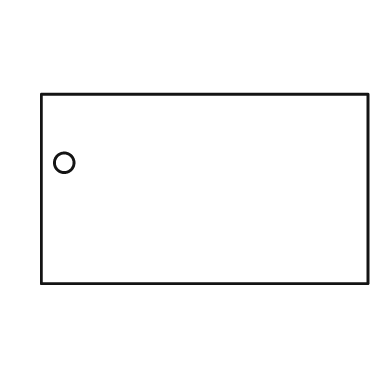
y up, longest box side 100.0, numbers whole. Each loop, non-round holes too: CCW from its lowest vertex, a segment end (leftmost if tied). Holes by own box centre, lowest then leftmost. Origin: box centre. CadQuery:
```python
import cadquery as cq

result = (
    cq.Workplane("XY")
    .moveTo(-50.0, -29.0)
    .lineTo(50.0, -29.0)
    .lineTo(50.0, 29.0)
    .lineTo(-50.0, 29.0)
    .close()
    .moveTo(-43.0, 8.0)
    .circle(3.0)
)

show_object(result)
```